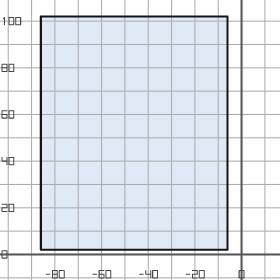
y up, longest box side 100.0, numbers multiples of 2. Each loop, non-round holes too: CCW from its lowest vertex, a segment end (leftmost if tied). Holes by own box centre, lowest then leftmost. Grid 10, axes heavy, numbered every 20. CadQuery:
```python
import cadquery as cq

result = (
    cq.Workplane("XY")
    .moveTo(-86.0, 2.0)
    .lineTo(-6.0, 2.0)
    .lineTo(-6.0, 102.0)
    .lineTo(-86.0, 102.0)
    .close()
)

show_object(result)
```